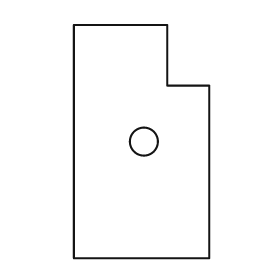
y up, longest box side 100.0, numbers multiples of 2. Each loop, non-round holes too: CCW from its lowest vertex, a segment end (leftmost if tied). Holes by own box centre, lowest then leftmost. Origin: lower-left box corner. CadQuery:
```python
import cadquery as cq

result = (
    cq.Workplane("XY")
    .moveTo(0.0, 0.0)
    .lineTo(58.0, 0.0)
    .lineTo(58.0, 74.0)
    .lineTo(40.0, 74.0)
    .lineTo(40.0, 100.0)
    .lineTo(0.0, 100.0)
    .close()
    .moveTo(30.0, 50.0)
    .circle(6.0)
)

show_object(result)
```